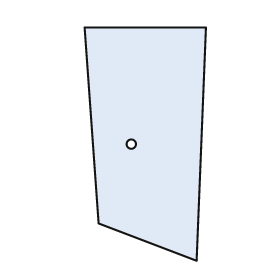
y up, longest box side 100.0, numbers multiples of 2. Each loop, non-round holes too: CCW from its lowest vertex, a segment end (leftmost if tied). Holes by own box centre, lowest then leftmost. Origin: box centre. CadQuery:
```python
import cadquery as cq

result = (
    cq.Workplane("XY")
    .moveTo(22.0, -50.0)
    .lineTo(26.0, 50.0)
    .lineTo(-26.0, 50.0)
    .lineTo(-20.0, -34.0)
    .close()
    .moveTo(-6.0, 0.0)
    .circle(2.0)
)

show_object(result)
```